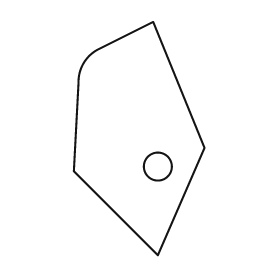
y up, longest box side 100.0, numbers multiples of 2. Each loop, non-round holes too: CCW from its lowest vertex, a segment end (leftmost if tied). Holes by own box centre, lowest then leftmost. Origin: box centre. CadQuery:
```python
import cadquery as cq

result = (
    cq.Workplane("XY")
    .moveTo(8.0, -50.0)
    .lineTo(28.0, -4.0)
    .lineTo(6.0, 50.0)
    .lineTo(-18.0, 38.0)
    .threePointArc((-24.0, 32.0), (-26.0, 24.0))
    .lineTo(-28.0, -14.0)
    .close()
    .moveTo(8.0, -12.0)
    .circle(6.0)
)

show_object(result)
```